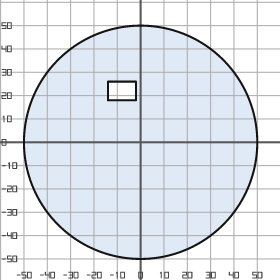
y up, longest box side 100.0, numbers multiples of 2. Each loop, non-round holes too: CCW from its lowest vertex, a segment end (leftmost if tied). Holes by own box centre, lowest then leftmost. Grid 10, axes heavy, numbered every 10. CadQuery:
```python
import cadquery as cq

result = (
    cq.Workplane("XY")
    .moveTo(0.0, 0.0)
    .circle(50.0)
    .moveTo(-14.0, 18.0)
    .lineTo(-2.0, 18.0)
    .lineTo(-2.0, 26.0)
    .lineTo(-14.0, 26.0)
    .close()
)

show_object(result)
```